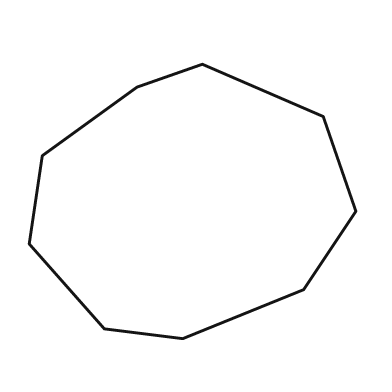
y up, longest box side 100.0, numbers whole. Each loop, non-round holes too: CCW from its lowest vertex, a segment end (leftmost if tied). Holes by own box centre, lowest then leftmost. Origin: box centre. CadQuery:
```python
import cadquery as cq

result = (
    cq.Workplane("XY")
    .moveTo(-3.0, -42.0)
    .lineTo(34.0, -27.0)
    .lineTo(50.0, -3.0)
    .lineTo(40.0, 26.0)
    .lineTo(3.0, 42.0)
    .lineTo(-17.0, 35.0)
    .lineTo(-46.0, 14.0)
    .lineTo(-50.0, -13.0)
    .lineTo(-27.0, -39.0)
    .close()
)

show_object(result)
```